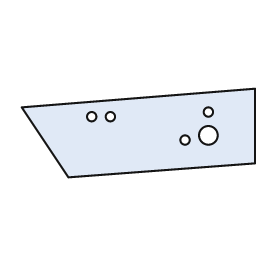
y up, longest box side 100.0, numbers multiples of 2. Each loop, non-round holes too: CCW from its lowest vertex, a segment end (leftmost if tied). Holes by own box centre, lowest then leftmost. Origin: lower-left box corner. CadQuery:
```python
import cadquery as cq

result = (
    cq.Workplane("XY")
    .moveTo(20.0, 0.0)
    .lineTo(100.0, 6.0)
    .lineTo(100.0, 38.0)
    .lineTo(0.0, 30.0)
    .close()
    .moveTo(70.0, 16.0)
    .circle(2.0)
    .moveTo(80.0, 18.0)
    .circle(4.0)
    .moveTo(30.0, 26.0)
    .circle(2.0)
    .moveTo(38.0, 26.0)
    .circle(2.0)
    .moveTo(80.0, 28.0)
    .circle(2.0)
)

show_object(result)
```